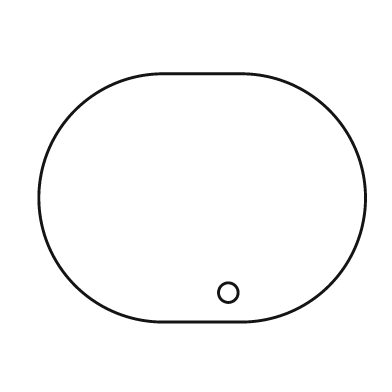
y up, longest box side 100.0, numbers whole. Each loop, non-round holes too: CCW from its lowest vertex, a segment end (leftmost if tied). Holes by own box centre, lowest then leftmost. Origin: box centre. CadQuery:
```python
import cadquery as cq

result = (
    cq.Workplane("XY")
    .moveTo(-12.0, -38.0)
    .lineTo(12.0, -38.0)
    .threePointArc((50.0, 0.0), (12.0, 38.0))
    .lineTo(-12.0, 38.0)
    .threePointArc((-50.0, 0.0), (-12.0, -38.0))
    .close()
    .moveTo(8.0, -29.0)
    .circle(3.0)
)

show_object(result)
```